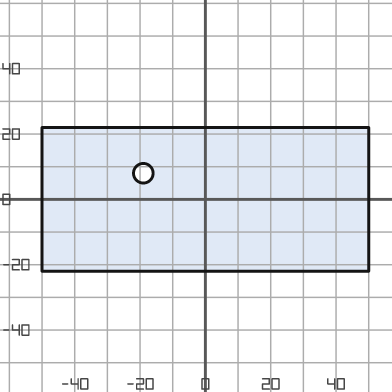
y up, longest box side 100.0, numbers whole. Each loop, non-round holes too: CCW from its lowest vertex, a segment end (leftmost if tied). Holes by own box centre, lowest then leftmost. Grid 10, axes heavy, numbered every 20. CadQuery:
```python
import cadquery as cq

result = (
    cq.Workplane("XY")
    .moveTo(-50.0, -22.0)
    .lineTo(50.0, -22.0)
    .lineTo(50.0, 22.0)
    .lineTo(-50.0, 22.0)
    .close()
    .moveTo(-19.0, 8.0)
    .circle(3.0)
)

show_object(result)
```